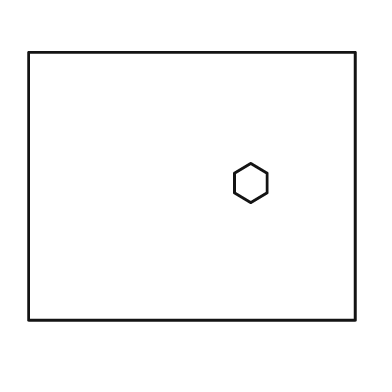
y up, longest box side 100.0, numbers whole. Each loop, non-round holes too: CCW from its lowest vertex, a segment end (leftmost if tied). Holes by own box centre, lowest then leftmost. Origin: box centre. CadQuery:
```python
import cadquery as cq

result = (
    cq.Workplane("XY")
    .moveTo(-50.0, -41.0)
    .lineTo(50.0, -41.0)
    .lineTo(50.0, 41.0)
    .lineTo(-50.0, 41.0)
    .close()
    .moveTo(18.0, -5.0)
    .lineTo(23.0, -2.0)
    .lineTo(23.0, 4.0)
    .lineTo(18.0, 7.0)
    .lineTo(13.0, 4.0)
    .lineTo(13.0, -2.0)
    .close()
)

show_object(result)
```